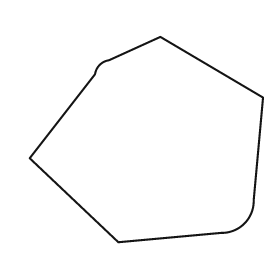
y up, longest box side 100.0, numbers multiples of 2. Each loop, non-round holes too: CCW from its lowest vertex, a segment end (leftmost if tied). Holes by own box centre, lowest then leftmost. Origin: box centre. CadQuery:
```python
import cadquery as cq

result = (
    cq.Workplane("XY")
    .moveTo(-12.0, -44.0)
    .lineTo(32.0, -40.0)
    .threePointArc((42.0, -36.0), (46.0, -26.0))
    .lineTo(50.0, 18.0)
    .lineTo(6.0, 44.0)
    .lineTo(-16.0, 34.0)
    .threePointArc((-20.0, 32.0), (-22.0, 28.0))
    .lineTo(-50.0, -8.0)
    .close()
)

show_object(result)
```